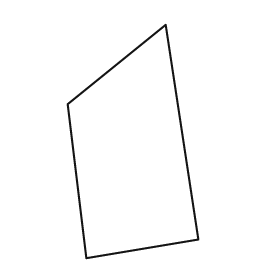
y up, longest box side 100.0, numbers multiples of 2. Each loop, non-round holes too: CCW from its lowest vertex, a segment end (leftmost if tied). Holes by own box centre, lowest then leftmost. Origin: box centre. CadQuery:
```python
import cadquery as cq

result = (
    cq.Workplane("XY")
    .moveTo(-20.0, -50.0)
    .lineTo(28.0, -42.0)
    .lineTo(14.0, 50.0)
    .lineTo(-28.0, 16.0)
    .close()
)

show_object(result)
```